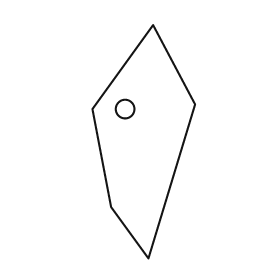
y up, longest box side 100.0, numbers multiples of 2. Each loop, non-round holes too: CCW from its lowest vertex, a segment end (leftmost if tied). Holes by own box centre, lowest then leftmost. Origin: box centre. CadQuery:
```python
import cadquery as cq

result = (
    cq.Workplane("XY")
    .moveTo(2.0, -50.0)
    .lineTo(22.0, 16.0)
    .lineTo(4.0, 50.0)
    .lineTo(-22.0, 14.0)
    .lineTo(-14.0, -28.0)
    .close()
    .moveTo(-8.0, 14.0)
    .circle(4.0)
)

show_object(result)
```